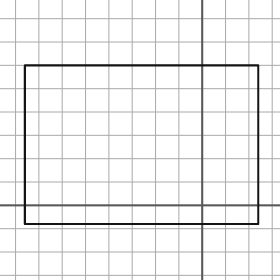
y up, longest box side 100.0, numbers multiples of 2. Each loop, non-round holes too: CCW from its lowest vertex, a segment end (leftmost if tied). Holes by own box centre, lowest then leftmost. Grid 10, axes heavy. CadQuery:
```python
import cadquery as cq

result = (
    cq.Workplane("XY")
    .moveTo(-76.0, -8.0)
    .lineTo(24.0, -8.0)
    .lineTo(24.0, 60.0)
    .lineTo(-76.0, 60.0)
    .close()
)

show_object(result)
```